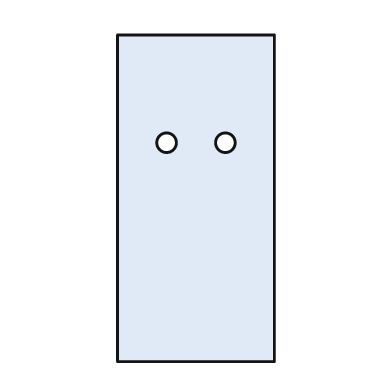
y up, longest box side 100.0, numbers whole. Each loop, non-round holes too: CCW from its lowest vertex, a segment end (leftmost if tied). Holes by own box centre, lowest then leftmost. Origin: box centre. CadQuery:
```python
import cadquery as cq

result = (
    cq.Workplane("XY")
    .moveTo(-24.0, -50.0)
    .lineTo(24.0, -50.0)
    .lineTo(24.0, 50.0)
    .lineTo(-24.0, 50.0)
    .close()
    .moveTo(-9.0, 17.0)
    .circle(3.0)
    .moveTo(9.0, 17.0)
    .circle(3.0)
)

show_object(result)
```